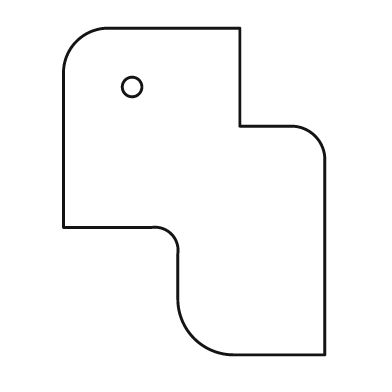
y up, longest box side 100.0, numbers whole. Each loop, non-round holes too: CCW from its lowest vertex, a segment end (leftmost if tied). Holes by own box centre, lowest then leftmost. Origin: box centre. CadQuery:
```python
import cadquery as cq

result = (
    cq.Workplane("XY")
    .moveTo(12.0, -50.0)
    .lineTo(40.0, -50.0)
    .lineTo(40.0, 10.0)
    .threePointArc((37.0, 17.0), (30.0, 20.0))
    .lineTo(14.0, 20.0)
    .lineTo(14.0, 50.0)
    .lineTo(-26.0, 50.0)
    .threePointArc((-36.0, 46.0), (-40.0, 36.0))
    .lineTo(-40.0, -11.0)
    .lineTo(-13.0, -11.0)
    .threePointArc((-7.0, -13.0), (-5.0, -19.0))
    .lineTo(-5.0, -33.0)
    .threePointArc((0.0, -45.0), (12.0, -50.0))
    .close()
    .moveTo(-19.0, 32.0)
    .circle(3.0)
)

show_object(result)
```